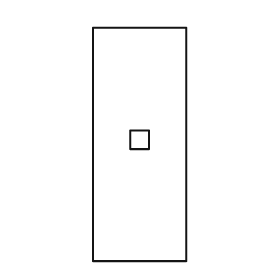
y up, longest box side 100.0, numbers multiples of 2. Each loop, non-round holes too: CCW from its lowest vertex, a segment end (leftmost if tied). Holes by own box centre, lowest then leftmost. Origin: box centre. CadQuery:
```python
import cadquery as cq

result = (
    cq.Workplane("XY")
    .moveTo(-20.0, -50.0)
    .lineTo(20.0, -50.0)
    .lineTo(20.0, 50.0)
    .lineTo(-20.0, 50.0)
    .close()
    .moveTo(-4.0, -2.0)
    .lineTo(4.0, -2.0)
    .lineTo(4.0, 6.0)
    .lineTo(-4.0, 6.0)
    .close()
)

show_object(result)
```